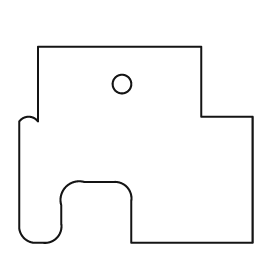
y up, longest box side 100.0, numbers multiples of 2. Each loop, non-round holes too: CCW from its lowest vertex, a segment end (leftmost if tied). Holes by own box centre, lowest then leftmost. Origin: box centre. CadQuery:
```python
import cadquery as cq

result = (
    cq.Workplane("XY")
    .moveTo(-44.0, -42.0)
    .lineTo(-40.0, -42.0)
    .threePointArc((-34.0, -40.0), (-32.0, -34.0))
    .lineTo(-32.0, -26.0)
    .threePointArc((-30.0, -18.0), (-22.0, -16.0))
    .lineTo(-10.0, -16.0)
    .threePointArc((-4.0, -18.0), (-2.0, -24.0))
    .lineTo(-2.0, -42.0)
    .lineTo(50.0, -42.0)
    .lineTo(50.0, 12.0)
    .lineTo(28.0, 12.0)
    .lineTo(28.0, 42.0)
    .lineTo(-42.0, 42.0)
    .lineTo(-42.0, 10.0)
    .threePointArc((-46.0, 12.0), (-50.0, 10.0))
    .lineTo(-50.0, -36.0)
    .threePointArc((-48.0, -40.0), (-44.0, -42.0))
    .close()
    .moveTo(-6.0, 26.0)
    .circle(4.0)
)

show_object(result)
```